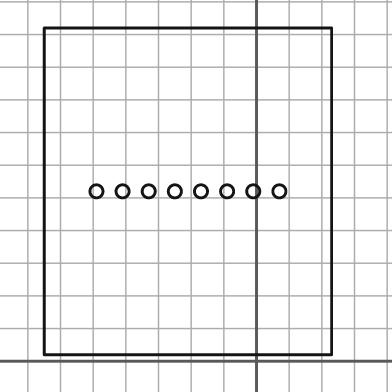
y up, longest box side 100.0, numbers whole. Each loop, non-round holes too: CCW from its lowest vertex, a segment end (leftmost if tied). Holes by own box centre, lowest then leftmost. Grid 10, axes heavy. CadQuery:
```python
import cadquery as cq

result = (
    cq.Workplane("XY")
    .moveTo(-65.0, 2.0)
    .lineTo(23.0, 2.0)
    .lineTo(23.0, 102.0)
    .lineTo(-65.0, 102.0)
    .close()
    .moveTo(-49.0, 52.0)
    .circle(2.0)
    .moveTo(-41.0, 52.0)
    .circle(2.0)
    .moveTo(-33.0, 52.0)
    .circle(2.0)
    .moveTo(-25.0, 52.0)
    .circle(2.0)
    .moveTo(-17.0, 52.0)
    .circle(2.0)
    .moveTo(-9.0, 52.0)
    .circle(2.0)
    .moveTo(-1.0, 52.0)
    .circle(2.0)
    .moveTo(7.0, 52.0)
    .circle(2.0)
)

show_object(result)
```